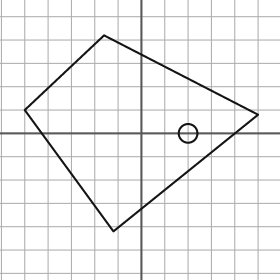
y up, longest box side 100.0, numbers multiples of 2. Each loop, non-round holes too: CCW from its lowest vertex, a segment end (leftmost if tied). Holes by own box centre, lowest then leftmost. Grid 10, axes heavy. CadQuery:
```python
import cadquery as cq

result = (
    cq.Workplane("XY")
    .moveTo(-12.0, -42.0)
    .lineTo(50.0, 8.0)
    .lineTo(-16.0, 42.0)
    .lineTo(-50.0, 10.0)
    .close()
    .moveTo(20.0, 0.0)
    .circle(4.0)
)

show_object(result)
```